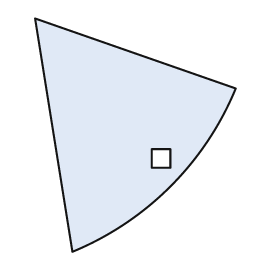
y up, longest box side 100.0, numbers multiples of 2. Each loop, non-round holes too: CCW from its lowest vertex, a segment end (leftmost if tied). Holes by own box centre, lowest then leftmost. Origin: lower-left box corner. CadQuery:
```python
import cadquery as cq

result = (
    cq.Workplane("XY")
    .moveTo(16.0, 0.0)
    .threePointArc((58.0, 28.0), (86.0, 70.0))
    .lineTo(0.0, 100.0)
    .close()
    .moveTo(50.0, 36.0)
    .lineTo(58.0, 36.0)
    .lineTo(58.0, 44.0)
    .lineTo(50.0, 44.0)
    .close()
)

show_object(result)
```